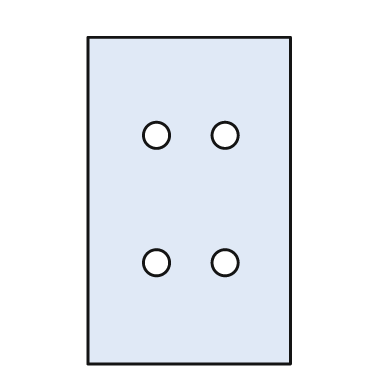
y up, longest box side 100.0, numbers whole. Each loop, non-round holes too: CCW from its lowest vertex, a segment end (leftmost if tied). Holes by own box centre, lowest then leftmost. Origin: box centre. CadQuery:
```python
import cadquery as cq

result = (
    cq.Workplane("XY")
    .moveTo(-31.0, -50.0)
    .lineTo(31.0, -50.0)
    .lineTo(31.0, 50.0)
    .lineTo(-31.0, 50.0)
    .close()
    .moveTo(-10.0, -19.0)
    .circle(4.0)
    .moveTo(11.0, -19.0)
    .circle(4.0)
    .moveTo(-10.0, 20.0)
    .circle(4.0)
    .moveTo(11.0, 20.0)
    .circle(4.0)
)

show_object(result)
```